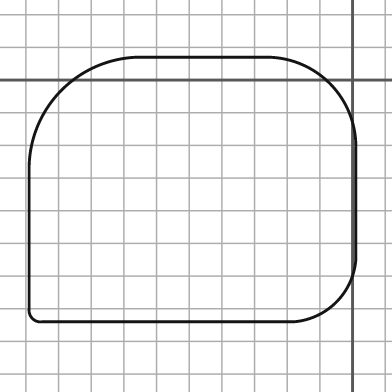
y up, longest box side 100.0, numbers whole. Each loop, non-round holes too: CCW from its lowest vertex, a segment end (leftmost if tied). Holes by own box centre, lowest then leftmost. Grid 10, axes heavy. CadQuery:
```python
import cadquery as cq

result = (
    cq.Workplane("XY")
    .moveTo(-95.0, -74.0)
    .lineTo(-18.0, -74.0)
    .threePointArc((-5.0, -68.0), (1.0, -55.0))
    .lineTo(1.0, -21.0)
    .threePointArc((-7.0, -1.0), (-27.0, 7.0))
    .lineTo(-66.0, 7.0)
    .threePointArc((-89.0, -3.0), (-99.0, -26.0))
    .lineTo(-99.0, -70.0)
    .threePointArc((-98.0, -73.0), (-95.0, -74.0))
    .close()
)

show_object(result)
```